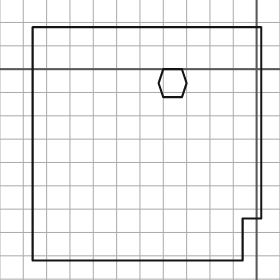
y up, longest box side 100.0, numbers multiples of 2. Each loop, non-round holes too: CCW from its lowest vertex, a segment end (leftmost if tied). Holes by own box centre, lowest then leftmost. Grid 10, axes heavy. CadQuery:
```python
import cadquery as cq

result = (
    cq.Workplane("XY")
    .moveTo(-96.0, -82.0)
    .lineTo(-6.0, -82.0)
    .lineTo(-6.0, -64.0)
    .lineTo(2.0, -64.0)
    .lineTo(2.0, 18.0)
    .lineTo(-96.0, 18.0)
    .close()
    .moveTo(-40.0, -12.0)
    .lineTo(-32.0, -12.0)
    .lineTo(-30.0, -6.0)
    .lineTo(-32.0, 0.0)
    .lineTo(-40.0, 0.0)
    .lineTo(-42.0, -6.0)
    .close()
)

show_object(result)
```